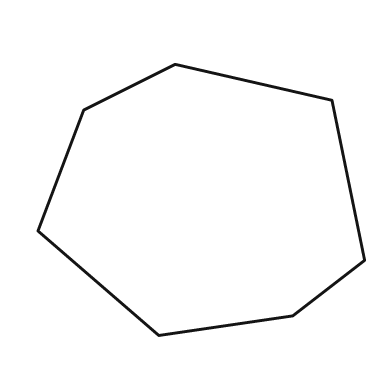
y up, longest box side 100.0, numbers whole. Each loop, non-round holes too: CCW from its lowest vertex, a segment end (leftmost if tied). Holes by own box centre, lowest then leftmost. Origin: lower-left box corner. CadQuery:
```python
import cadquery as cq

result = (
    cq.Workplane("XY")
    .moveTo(37.0, 0.0)
    .lineTo(78.0, 6.0)
    .lineTo(100.0, 23.0)
    .lineTo(90.0, 72.0)
    .lineTo(42.0, 83.0)
    .lineTo(14.0, 69.0)
    .lineTo(0.0, 32.0)
    .close()
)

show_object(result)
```